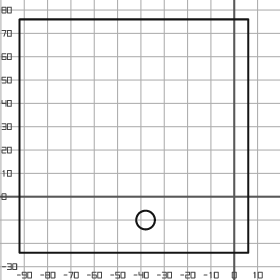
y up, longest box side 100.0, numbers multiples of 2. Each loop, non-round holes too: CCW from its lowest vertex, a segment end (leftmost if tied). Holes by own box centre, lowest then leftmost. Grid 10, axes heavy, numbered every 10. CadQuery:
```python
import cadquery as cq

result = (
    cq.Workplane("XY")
    .moveTo(-92.0, -24.0)
    .lineTo(6.0, -24.0)
    .lineTo(6.0, 76.0)
    .lineTo(-92.0, 76.0)
    .close()
    .moveTo(-38.0, -10.0)
    .circle(4.0)
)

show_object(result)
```